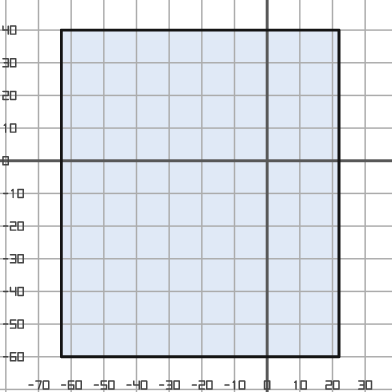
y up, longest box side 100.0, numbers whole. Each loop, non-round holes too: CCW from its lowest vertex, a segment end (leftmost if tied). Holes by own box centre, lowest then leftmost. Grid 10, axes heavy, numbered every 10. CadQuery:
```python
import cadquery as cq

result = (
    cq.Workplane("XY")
    .moveTo(-63.0, -60.0)
    .lineTo(22.0, -60.0)
    .lineTo(22.0, 40.0)
    .lineTo(-63.0, 40.0)
    .close()
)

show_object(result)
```